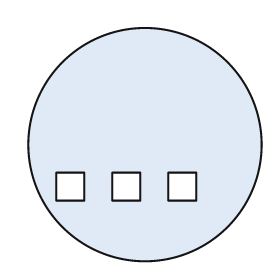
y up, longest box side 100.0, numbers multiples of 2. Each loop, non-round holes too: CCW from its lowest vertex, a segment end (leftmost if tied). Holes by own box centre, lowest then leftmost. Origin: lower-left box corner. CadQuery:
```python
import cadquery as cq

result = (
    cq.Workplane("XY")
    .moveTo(50.0, 50.0)
    .circle(50.0)
    .moveTo(12.0, 26.0)
    .lineTo(24.0, 26.0)
    .lineTo(24.0, 38.0)
    .lineTo(12.0, 38.0)
    .close()
    .moveTo(36.0, 26.0)
    .lineTo(48.0, 26.0)
    .lineTo(48.0, 38.0)
    .lineTo(36.0, 38.0)
    .close()
    .moveTo(60.0, 26.0)
    .lineTo(72.0, 26.0)
    .lineTo(72.0, 38.0)
    .lineTo(60.0, 38.0)
    .close()
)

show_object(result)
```